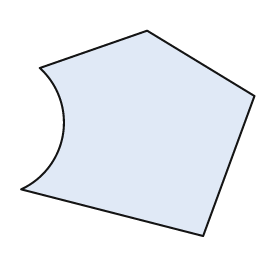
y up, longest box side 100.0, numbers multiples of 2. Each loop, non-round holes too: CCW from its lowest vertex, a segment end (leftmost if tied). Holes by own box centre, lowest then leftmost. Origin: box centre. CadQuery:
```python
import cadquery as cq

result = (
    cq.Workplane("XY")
    .moveTo(28.0, -44.0)
    .lineTo(50.0, 16.0)
    .lineTo(4.0, 44.0)
    .lineTo(-42.0, 28.0)
    .threePointArc((-32.0, 0.0), (-50.0, -24.0))
    .close()
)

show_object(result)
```